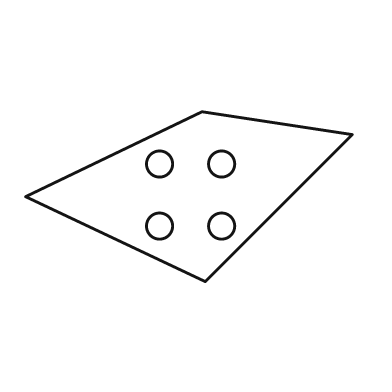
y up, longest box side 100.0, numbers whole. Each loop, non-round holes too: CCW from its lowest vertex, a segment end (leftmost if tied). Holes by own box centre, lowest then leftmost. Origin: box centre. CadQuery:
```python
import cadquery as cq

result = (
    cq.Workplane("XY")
    .moveTo(5.0, -26.0)
    .lineTo(50.0, 19.0)
    .lineTo(4.0, 26.0)
    .lineTo(-50.0, 0.0)
    .close()
    .moveTo(-9.0, -9.0)
    .circle(4.0)
    .moveTo(10.0, -9.0)
    .circle(4.0)
    .moveTo(-9.0, 10.0)
    .circle(4.0)
    .moveTo(10.0, 10.0)
    .circle(4.0)
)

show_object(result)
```